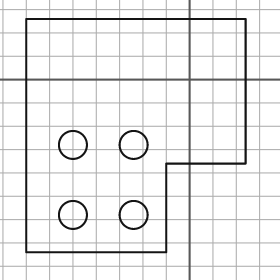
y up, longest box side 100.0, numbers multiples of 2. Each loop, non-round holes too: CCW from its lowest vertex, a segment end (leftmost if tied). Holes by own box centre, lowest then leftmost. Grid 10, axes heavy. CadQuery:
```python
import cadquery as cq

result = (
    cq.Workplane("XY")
    .moveTo(-70.0, -74.0)
    .lineTo(-10.0, -74.0)
    .lineTo(-10.0, -36.0)
    .lineTo(24.0, -36.0)
    .lineTo(24.0, 26.0)
    .lineTo(-70.0, 26.0)
    .close()
    .moveTo(-50.0, -58.0)
    .circle(6.0)
    .moveTo(-24.0, -58.0)
    .circle(6.0)
    .moveTo(-50.0, -28.0)
    .circle(6.0)
    .moveTo(-24.0, -28.0)
    .circle(6.0)
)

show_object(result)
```